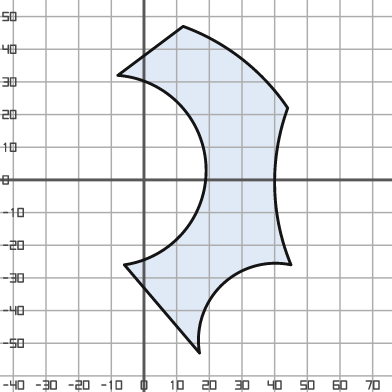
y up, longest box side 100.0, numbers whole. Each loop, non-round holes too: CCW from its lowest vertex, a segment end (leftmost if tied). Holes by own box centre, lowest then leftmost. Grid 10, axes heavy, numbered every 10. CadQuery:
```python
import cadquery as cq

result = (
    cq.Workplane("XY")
    .moveTo(17.0, -53.0)
    .threePointArc((24.0, -32.0), (45.0, -26.0))
    .threePointArc((40.0, -2.0), (44.0, 22.0))
    .threePointArc((30.0, 37.0), (12.0, 47.0))
    .lineTo(-8.0, 32.0)
    .threePointArc((19.0, 4.0), (-6.0, -26.0))
    .close()
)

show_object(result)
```